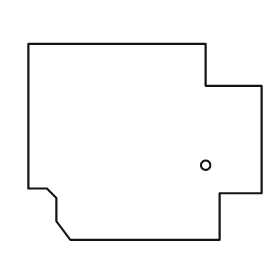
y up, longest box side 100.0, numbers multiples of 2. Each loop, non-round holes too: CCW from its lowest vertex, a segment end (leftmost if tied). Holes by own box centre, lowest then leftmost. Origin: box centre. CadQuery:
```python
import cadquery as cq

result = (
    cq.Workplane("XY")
    .moveTo(-32.0, -42.0)
    .lineTo(32.0, -42.0)
    .lineTo(32.0, -22.0)
    .lineTo(50.0, -22.0)
    .lineTo(50.0, 24.0)
    .lineTo(26.0, 24.0)
    .lineTo(26.0, 42.0)
    .lineTo(-50.0, 42.0)
    .lineTo(-50.0, -20.0)
    .lineTo(-42.0, -20.0)
    .lineTo(-38.0, -24.0)
    .lineTo(-38.0, -34.0)
    .close()
    .moveTo(26.0, -10.0)
    .circle(2.0)
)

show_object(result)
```